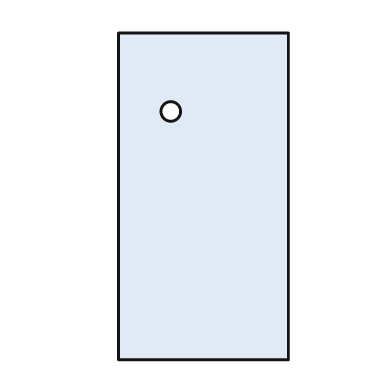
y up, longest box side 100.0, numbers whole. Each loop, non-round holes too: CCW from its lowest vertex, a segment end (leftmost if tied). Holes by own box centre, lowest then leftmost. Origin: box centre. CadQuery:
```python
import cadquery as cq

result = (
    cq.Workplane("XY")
    .moveTo(-26.0, -50.0)
    .lineTo(26.0, -50.0)
    .lineTo(26.0, 50.0)
    .lineTo(-26.0, 50.0)
    .close()
    .moveTo(-10.0, 26.0)
    .circle(3.0)
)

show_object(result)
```